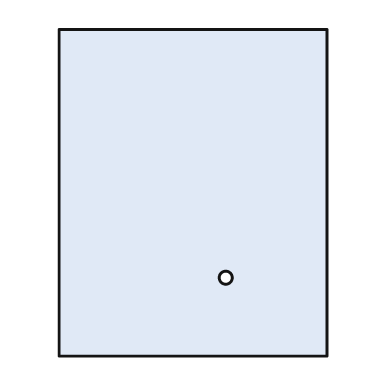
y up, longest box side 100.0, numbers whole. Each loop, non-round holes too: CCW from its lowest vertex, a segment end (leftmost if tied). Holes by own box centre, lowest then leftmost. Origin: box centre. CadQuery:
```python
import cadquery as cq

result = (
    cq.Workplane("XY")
    .moveTo(-41.0, -50.0)
    .lineTo(41.0, -50.0)
    .lineTo(41.0, 50.0)
    .lineTo(-41.0, 50.0)
    .close()
    .moveTo(10.0, -26.0)
    .circle(2.0)
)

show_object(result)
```